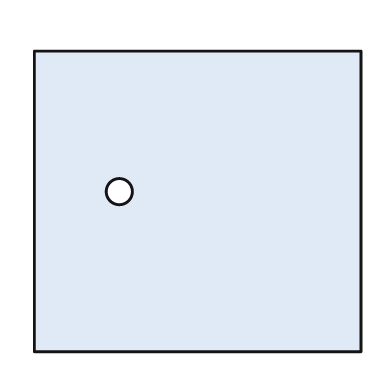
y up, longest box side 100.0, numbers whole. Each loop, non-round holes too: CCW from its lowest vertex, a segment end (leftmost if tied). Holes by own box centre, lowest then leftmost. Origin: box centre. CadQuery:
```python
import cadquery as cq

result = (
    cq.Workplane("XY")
    .moveTo(-50.0, -46.0)
    .lineTo(50.0, -46.0)
    .lineTo(50.0, 46.0)
    .lineTo(-50.0, 46.0)
    .close()
    .moveTo(-24.0, 3.0)
    .circle(4.0)
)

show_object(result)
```